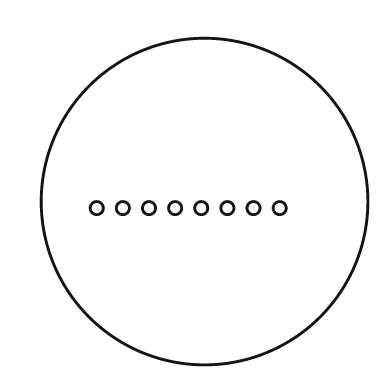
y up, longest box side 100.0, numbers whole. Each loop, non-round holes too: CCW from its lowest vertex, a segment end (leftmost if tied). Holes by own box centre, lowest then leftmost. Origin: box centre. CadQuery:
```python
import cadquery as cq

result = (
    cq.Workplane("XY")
    .moveTo(0.0, 0.0)
    .circle(50.0)
    .moveTo(-33.0, -2.0)
    .circle(2.0)
    .moveTo(-25.0, -2.0)
    .circle(2.0)
    .moveTo(-17.0, -2.0)
    .circle(2.0)
    .moveTo(-9.0, -2.0)
    .circle(2.0)
    .moveTo(-1.0, -2.0)
    .circle(2.0)
    .moveTo(7.0, -2.0)
    .circle(2.0)
    .moveTo(15.0, -2.0)
    .circle(2.0)
    .moveTo(23.0, -2.0)
    .circle(2.0)
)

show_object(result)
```